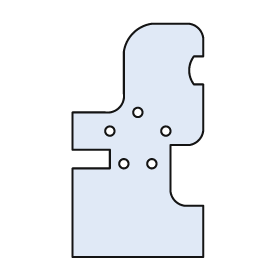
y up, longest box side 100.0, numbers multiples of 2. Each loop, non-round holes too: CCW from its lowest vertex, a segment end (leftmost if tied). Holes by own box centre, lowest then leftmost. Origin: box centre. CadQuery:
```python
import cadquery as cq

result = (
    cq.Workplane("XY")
    .moveTo(-28.0, -50.0)
    .lineTo(28.0, -50.0)
    .lineTo(28.0, -28.0)
    .lineTo(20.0, -28.0)
    .threePointArc((16.0, -26.0), (14.0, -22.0))
    .lineTo(14.0, -2.0)
    .lineTo(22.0, -2.0)
    .threePointArc((26.0, 0.0), (28.0, 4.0))
    .lineTo(28.0, 24.0)
    .lineTo(24.0, 24.0)
    .threePointArc((22.0, 30.0), (24.0, 36.0))
    .lineTo(28.0, 36.0)
    .lineTo(28.0, 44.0)
    .threePointArc((26.0, 48.0), (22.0, 50.0))
    .lineTo(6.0, 50.0)
    .threePointArc((-2.0, 46.0), (-6.0, 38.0))
    .lineTo(-6.0, 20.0)
    .threePointArc((-8.0, 14.0), (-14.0, 12.0))
    .lineTo(-28.0, 12.0)
    .lineTo(-28.0, -4.0)
    .lineTo(-12.0, -4.0)
    .lineTo(-12.0, -12.0)
    .lineTo(-28.0, -12.0)
    .close()
    .moveTo(-6.0, -10.0)
    .circle(2.0)
    .moveTo(6.0, -10.0)
    .circle(2.0)
    .moveTo(-12.0, 4.0)
    .circle(2.0)
    .moveTo(12.0, 4.0)
    .circle(2.0)
    .moveTo(0.0, 12.0)
    .circle(2.0)
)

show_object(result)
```